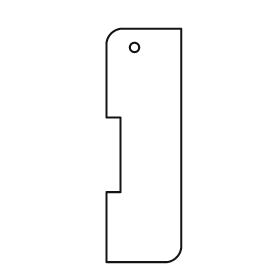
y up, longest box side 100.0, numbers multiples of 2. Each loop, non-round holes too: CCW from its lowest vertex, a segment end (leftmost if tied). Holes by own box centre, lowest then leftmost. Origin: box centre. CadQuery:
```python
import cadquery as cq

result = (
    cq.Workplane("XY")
    .moveTo(-16.0, -50.0)
    .lineTo(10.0, -50.0)
    .threePointArc((14.0, -48.0), (16.0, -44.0))
    .lineTo(16.0, 50.0)
    .lineTo(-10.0, 50.0)
    .threePointArc((-14.0, 48.0), (-16.0, 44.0))
    .lineTo(-16.0, 12.0)
    .lineTo(-10.0, 12.0)
    .lineTo(-10.0, -20.0)
    .lineTo(-16.0, -20.0)
    .close()
    .moveTo(-4.0, 42.0)
    .circle(2.0)
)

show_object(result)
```